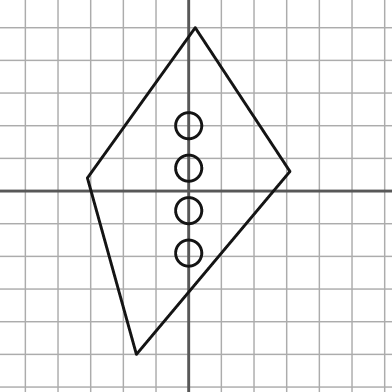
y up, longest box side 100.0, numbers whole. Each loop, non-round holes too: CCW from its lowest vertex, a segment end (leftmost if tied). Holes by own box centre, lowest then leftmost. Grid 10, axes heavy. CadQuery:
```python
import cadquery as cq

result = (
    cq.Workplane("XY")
    .moveTo(-16.0, -50.0)
    .lineTo(31.0, 6.0)
    .lineTo(2.0, 50.0)
    .lineTo(-31.0, 4.0)
    .close()
    .moveTo(0.0, -19.0)
    .circle(4.0)
    .moveTo(0.0, -6.0)
    .circle(4.0)
    .moveTo(0.0, 7.0)
    .circle(4.0)
    .moveTo(0.0, 20.0)
    .circle(4.0)
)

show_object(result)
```